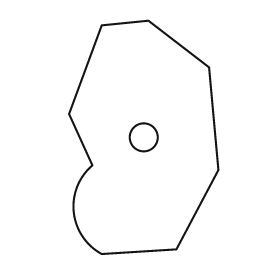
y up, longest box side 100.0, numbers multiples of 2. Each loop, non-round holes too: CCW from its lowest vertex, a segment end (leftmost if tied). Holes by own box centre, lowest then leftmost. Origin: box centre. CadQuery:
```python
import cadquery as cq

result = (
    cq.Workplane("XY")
    .moveTo(-18.0, -50.0)
    .lineTo(14.0, -48.0)
    .lineTo(32.0, -14.0)
    .lineTo(28.0, 30.0)
    .lineTo(2.0, 50.0)
    .lineTo(-18.0, 48.0)
    .lineTo(-32.0, 10.0)
    .lineTo(-22.0, -12.0)
    .threePointArc((-30.0, -32.0), (-18.0, -50.0))
    .close()
    .moveTo(0.0, 0.0)
    .circle(6.0)
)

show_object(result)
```